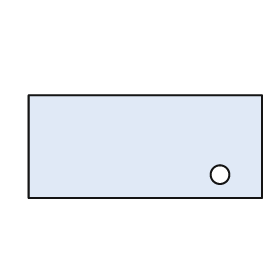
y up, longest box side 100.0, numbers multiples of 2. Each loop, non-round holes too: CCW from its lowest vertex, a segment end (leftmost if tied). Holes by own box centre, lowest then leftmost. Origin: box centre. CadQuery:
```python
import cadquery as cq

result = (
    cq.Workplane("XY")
    .moveTo(-50.0, -22.0)
    .lineTo(50.0, -22.0)
    .lineTo(50.0, 22.0)
    .lineTo(-50.0, 22.0)
    .close()
    .moveTo(32.0, -12.0)
    .circle(4.0)
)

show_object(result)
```